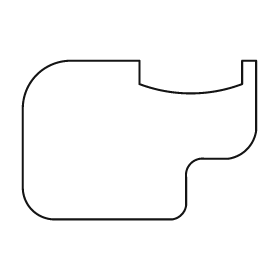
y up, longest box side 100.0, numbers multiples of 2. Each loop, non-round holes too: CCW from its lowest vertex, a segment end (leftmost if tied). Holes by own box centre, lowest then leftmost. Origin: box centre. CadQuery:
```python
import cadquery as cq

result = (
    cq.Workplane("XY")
    .moveTo(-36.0, -34.0)
    .lineTo(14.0, -34.0)
    .threePointArc((18.0, -32.0), (20.0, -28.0))
    .lineTo(20.0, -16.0)
    .threePointArc((22.0, -10.0), (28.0, -8.0))
    .lineTo(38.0, -8.0)
    .threePointArc((46.0, -4.0), (50.0, 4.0))
    .lineTo(50.0, 34.0)
    .lineTo(44.0, 34.0)
    .lineTo(44.0, 24.0)
    .threePointArc((22.0, 20.0), (0.0, 24.0))
    .lineTo(0.0, 34.0)
    .lineTo(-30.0, 34.0)
    .threePointArc((-44.0, 28.0), (-50.0, 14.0))
    .lineTo(-50.0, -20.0)
    .threePointArc((-46.0, -30.0), (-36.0, -34.0))
    .close()
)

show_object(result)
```